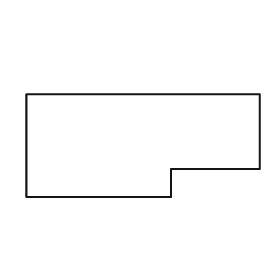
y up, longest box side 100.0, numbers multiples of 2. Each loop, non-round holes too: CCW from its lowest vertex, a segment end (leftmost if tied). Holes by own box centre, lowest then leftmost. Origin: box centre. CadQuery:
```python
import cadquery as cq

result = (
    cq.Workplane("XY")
    .moveTo(-50.0, -22.0)
    .lineTo(12.0, -22.0)
    .lineTo(12.0, -10.0)
    .lineTo(50.0, -10.0)
    .lineTo(50.0, 22.0)
    .lineTo(-50.0, 22.0)
    .close()
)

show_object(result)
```